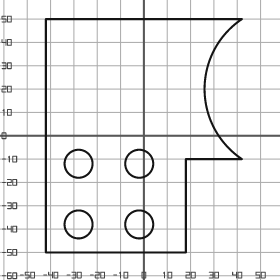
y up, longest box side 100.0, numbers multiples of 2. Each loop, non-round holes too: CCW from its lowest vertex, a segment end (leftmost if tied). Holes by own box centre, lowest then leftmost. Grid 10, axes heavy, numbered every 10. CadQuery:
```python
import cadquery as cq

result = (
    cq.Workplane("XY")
    .moveTo(-42.0, -50.0)
    .lineTo(18.0, -50.0)
    .lineTo(18.0, -10.0)
    .lineTo(42.0, -10.0)
    .threePointArc((26.0, 20.0), (42.0, 50.0))
    .lineTo(-42.0, 50.0)
    .close()
    .moveTo(-28.0, -38.0)
    .circle(6.0)
    .moveTo(-2.0, -38.0)
    .circle(6.0)
    .moveTo(-28.0, -12.0)
    .circle(6.0)
    .moveTo(-2.0, -12.0)
    .circle(6.0)
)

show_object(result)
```